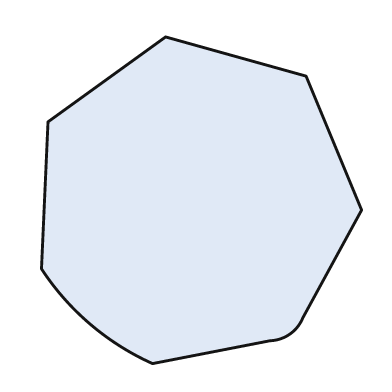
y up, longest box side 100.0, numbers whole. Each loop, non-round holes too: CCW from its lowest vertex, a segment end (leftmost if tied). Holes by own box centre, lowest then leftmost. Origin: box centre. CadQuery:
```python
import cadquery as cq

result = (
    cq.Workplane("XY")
    .moveTo(-15.0, -50.0)
    .lineTo(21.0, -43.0)
    .threePointArc((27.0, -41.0), (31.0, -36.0))
    .lineTo(49.0, -3.0)
    .lineTo(32.0, 38.0)
    .lineTo(-11.0, 50.0)
    .lineTo(-47.0, 24.0)
    .lineTo(-49.0, -21.0)
    .threePointArc((-34.0, -38.0), (-15.0, -50.0))
    .close()
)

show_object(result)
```